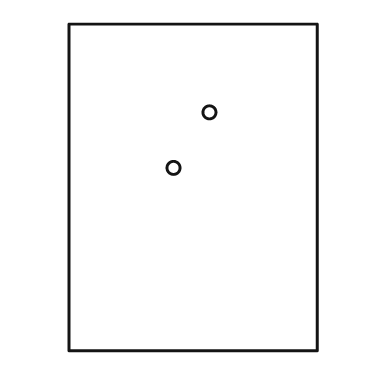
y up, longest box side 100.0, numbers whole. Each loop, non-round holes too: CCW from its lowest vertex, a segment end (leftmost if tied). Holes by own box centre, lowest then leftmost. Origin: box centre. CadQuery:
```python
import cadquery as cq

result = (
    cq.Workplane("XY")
    .moveTo(-38.0, -50.0)
    .lineTo(38.0, -50.0)
    .lineTo(38.0, 50.0)
    .lineTo(-38.0, 50.0)
    .close()
    .moveTo(-6.0, 6.0)
    .circle(2.0)
    .moveTo(5.0, 23.0)
    .circle(2.0)
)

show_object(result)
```